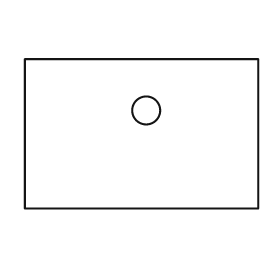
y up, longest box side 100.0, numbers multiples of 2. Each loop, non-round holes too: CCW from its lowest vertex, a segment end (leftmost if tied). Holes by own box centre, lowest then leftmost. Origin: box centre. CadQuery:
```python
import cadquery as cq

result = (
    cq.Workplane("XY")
    .moveTo(-50.0, -32.0)
    .lineTo(50.0, -32.0)
    .lineTo(50.0, 32.0)
    .lineTo(-50.0, 32.0)
    .close()
    .moveTo(2.0, 10.0)
    .circle(6.0)
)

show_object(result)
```